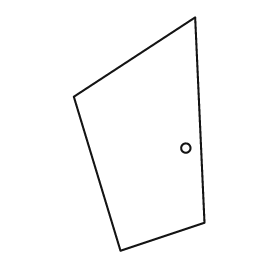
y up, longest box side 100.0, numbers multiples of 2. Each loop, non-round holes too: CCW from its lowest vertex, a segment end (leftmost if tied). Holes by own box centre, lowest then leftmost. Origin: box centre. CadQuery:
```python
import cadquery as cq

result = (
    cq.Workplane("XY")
    .moveTo(-8.0, -50.0)
    .lineTo(28.0, -38.0)
    .lineTo(24.0, 50.0)
    .lineTo(-28.0, 16.0)
    .close()
    .moveTo(20.0, -6.0)
    .circle(2.0)
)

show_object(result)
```